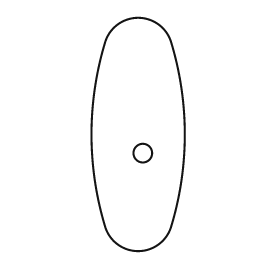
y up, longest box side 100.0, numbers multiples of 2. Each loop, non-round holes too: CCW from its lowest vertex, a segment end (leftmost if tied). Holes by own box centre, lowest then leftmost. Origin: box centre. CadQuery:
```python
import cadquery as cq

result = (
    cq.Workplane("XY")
    .moveTo(-14.0, -40.0)
    .threePointArc((0.0, -50.0), (14.0, -40.0))
    .threePointArc((20.0, 0.0), (14.0, 40.0))
    .threePointArc((0.0, 50.0), (-14.0, 40.0))
    .threePointArc((-20.0, 0.0), (-14.0, -40.0))
    .close()
    .moveTo(2.0, -8.0)
    .circle(4.0)
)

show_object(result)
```